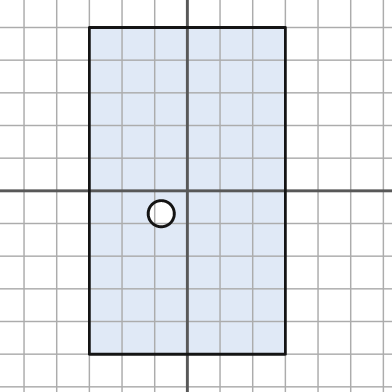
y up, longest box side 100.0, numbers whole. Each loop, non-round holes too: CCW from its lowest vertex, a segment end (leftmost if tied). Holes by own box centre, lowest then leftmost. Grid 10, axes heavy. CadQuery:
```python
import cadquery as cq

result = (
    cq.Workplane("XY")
    .moveTo(-30.0, -50.0)
    .lineTo(30.0, -50.0)
    .lineTo(30.0, 50.0)
    .lineTo(-30.0, 50.0)
    .close()
    .moveTo(-8.0, -7.0)
    .circle(4.0)
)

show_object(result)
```